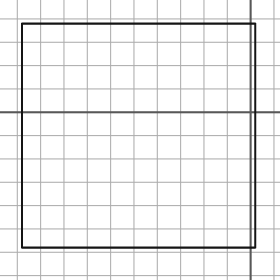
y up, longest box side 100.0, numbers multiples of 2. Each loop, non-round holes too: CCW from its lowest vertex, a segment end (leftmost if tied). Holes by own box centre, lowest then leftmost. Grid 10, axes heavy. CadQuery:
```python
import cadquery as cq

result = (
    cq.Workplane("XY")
    .moveTo(-98.0, -58.0)
    .lineTo(2.0, -58.0)
    .lineTo(2.0, 38.0)
    .lineTo(-98.0, 38.0)
    .close()
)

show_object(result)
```